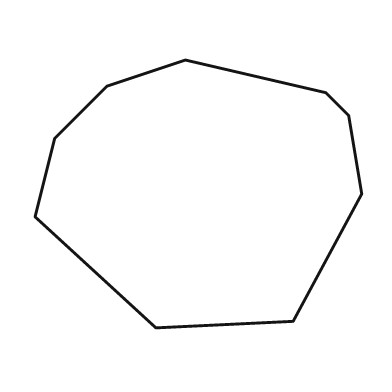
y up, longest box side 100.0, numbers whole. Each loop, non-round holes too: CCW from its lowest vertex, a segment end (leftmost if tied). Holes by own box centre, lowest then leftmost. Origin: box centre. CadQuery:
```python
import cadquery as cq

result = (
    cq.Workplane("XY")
    .moveTo(-13.0, -41.0)
    .lineTo(29.0, -39.0)
    .lineTo(50.0, 0.0)
    .lineTo(46.0, 24.0)
    .lineTo(39.0, 31.0)
    .lineTo(-4.0, 41.0)
    .lineTo(-28.0, 33.0)
    .lineTo(-44.0, 17.0)
    .lineTo(-50.0, -7.0)
    .close()
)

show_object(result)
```